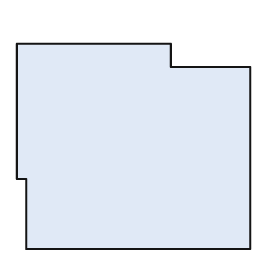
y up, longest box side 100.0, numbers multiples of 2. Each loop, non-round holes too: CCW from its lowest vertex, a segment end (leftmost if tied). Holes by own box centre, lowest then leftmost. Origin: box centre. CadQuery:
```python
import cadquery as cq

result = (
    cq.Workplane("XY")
    .moveTo(-46.0, -44.0)
    .lineTo(50.0, -44.0)
    .lineTo(50.0, 34.0)
    .lineTo(16.0, 34.0)
    .lineTo(16.0, 44.0)
    .lineTo(-50.0, 44.0)
    .lineTo(-50.0, -14.0)
    .lineTo(-46.0, -14.0)
    .close()
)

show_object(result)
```